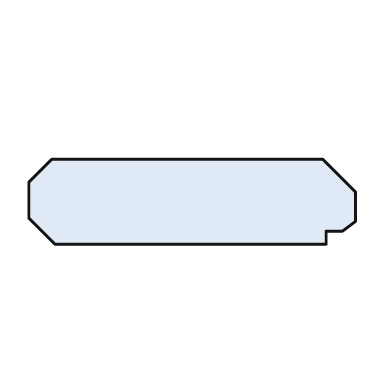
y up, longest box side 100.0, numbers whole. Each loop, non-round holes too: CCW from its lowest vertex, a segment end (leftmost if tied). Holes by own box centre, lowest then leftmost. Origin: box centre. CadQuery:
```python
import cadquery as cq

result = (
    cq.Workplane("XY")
    .moveTo(-42.0, -13.0)
    .lineTo(41.0, -13.0)
    .lineTo(41.0, -9.0)
    .lineTo(46.0, -9.0)
    .lineTo(50.0, -6.0)
    .lineTo(50.0, 3.0)
    .lineTo(40.0, 13.0)
    .lineTo(-43.0, 13.0)
    .lineTo(-50.0, 6.0)
    .lineTo(-50.0, -5.0)
    .close()
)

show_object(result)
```